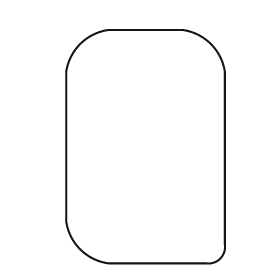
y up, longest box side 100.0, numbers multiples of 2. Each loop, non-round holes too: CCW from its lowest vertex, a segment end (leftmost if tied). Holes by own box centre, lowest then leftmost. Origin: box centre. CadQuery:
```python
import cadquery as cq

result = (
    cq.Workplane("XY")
    .moveTo(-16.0, -50.0)
    .lineTo(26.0, -50.0)
    .threePointArc((32.0, -48.0), (34.0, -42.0))
    .lineTo(34.0, 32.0)
    .threePointArc((28.0, 44.0), (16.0, 50.0))
    .lineTo(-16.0, 50.0)
    .threePointArc((-28.0, 44.0), (-34.0, 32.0))
    .lineTo(-34.0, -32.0)
    .threePointArc((-28.0, -44.0), (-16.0, -50.0))
    .close()
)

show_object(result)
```